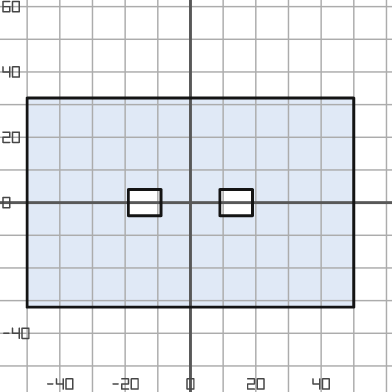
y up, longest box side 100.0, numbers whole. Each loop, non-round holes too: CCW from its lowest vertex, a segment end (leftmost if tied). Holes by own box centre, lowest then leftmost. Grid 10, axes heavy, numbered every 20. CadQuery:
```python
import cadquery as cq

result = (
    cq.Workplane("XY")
    .moveTo(-50.0, -32.0)
    .lineTo(50.0, -32.0)
    .lineTo(50.0, 32.0)
    .lineTo(-50.0, 32.0)
    .close()
    .moveTo(-19.0, -4.0)
    .lineTo(-9.0, -4.0)
    .lineTo(-9.0, 4.0)
    .lineTo(-19.0, 4.0)
    .close()
    .moveTo(9.0, -4.0)
    .lineTo(19.0, -4.0)
    .lineTo(19.0, 4.0)
    .lineTo(9.0, 4.0)
    .close()
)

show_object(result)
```